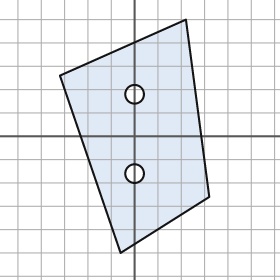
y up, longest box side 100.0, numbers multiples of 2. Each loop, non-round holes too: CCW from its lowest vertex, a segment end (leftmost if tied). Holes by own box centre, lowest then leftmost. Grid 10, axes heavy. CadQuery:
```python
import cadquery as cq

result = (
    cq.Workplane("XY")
    .moveTo(-6.0, -50.0)
    .lineTo(32.0, -26.0)
    .lineTo(22.0, 50.0)
    .lineTo(-32.0, 26.0)
    .close()
    .moveTo(0.0, -16.0)
    .circle(4.0)
    .moveTo(0.0, 18.0)
    .circle(4.0)
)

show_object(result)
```